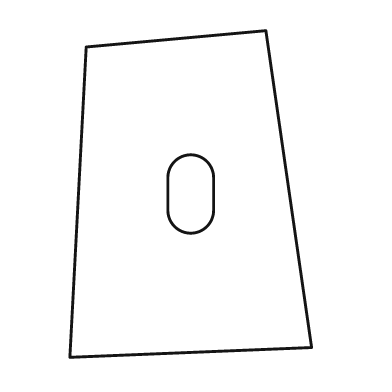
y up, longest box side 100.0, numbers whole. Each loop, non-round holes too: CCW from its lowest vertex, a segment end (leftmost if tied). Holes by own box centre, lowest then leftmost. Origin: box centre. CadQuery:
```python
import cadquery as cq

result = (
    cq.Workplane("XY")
    .moveTo(-37.0, -50.0)
    .lineTo(37.0, -47.0)
    .lineTo(23.0, 50.0)
    .lineTo(-32.0, 45.0)
    .close()
    .moveTo(-7.0, -5.0)
    .threePointArc((0.0, -12.0), (7.0, -5.0))
    .lineTo(7.0, 5.0)
    .threePointArc((0.0, 12.0), (-7.0, 5.0))
    .close()
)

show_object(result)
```